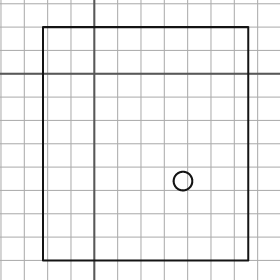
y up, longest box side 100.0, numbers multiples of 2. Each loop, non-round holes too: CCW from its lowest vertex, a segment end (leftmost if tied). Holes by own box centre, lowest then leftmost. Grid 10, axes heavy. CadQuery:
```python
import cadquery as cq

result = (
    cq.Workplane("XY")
    .moveTo(-22.0, -80.0)
    .lineTo(66.0, -80.0)
    .lineTo(66.0, 20.0)
    .lineTo(-22.0, 20.0)
    .close()
    .moveTo(38.0, -46.0)
    .circle(4.0)
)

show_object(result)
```